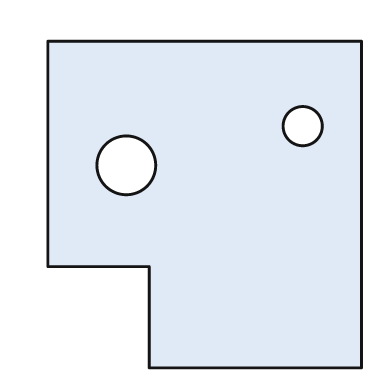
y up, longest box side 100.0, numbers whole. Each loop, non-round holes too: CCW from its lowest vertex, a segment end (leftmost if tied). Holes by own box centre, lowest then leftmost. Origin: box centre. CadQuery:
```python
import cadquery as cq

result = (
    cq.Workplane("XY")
    .moveTo(-17.0, -50.0)
    .lineTo(48.0, -50.0)
    .lineTo(48.0, 50.0)
    .lineTo(-48.0, 50.0)
    .lineTo(-48.0, -19.0)
    .lineTo(-17.0, -19.0)
    .close()
    .moveTo(-24.0, 12.0)
    .circle(9.0)
    .moveTo(30.0, 24.0)
    .circle(6.0)
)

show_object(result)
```